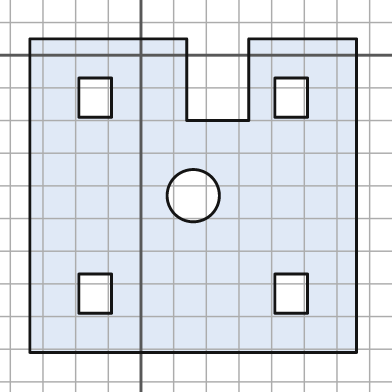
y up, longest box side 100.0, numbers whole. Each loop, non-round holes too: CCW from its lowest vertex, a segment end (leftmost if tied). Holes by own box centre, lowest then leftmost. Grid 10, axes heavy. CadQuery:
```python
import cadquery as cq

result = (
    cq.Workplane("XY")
    .moveTo(-34.0, -91.0)
    .lineTo(66.0, -91.0)
    .lineTo(66.0, 5.0)
    .lineTo(33.0, 5.0)
    .lineTo(33.0, -20.0)
    .lineTo(14.0, -20.0)
    .lineTo(14.0, 5.0)
    .lineTo(-34.0, 5.0)
    .close()
    .moveTo(-19.0, -79.0)
    .lineTo(-9.0, -79.0)
    .lineTo(-9.0, -67.0)
    .lineTo(-19.0, -67.0)
    .close()
    .moveTo(41.0, -79.0)
    .lineTo(51.0, -79.0)
    .lineTo(51.0, -67.0)
    .lineTo(41.0, -67.0)
    .close()
    .moveTo(16.0, -43.0)
    .circle(8.0)
    .moveTo(-19.0, -19.0)
    .lineTo(-9.0, -19.0)
    .lineTo(-9.0, -7.0)
    .lineTo(-19.0, -7.0)
    .close()
    .moveTo(41.0, -19.0)
    .lineTo(51.0, -19.0)
    .lineTo(51.0, -7.0)
    .lineTo(41.0, -7.0)
    .close()
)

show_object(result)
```